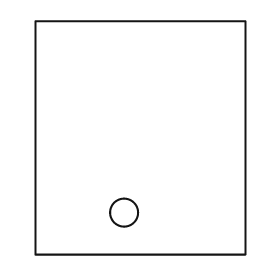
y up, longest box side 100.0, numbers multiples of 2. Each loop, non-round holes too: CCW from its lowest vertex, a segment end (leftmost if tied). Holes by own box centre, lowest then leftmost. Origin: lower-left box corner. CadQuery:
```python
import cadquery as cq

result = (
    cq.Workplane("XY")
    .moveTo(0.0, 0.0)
    .lineTo(90.0, 0.0)
    .lineTo(90.0, 100.0)
    .lineTo(0.0, 100.0)
    .close()
    .moveTo(38.0, 18.0)
    .circle(6.0)
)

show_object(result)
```